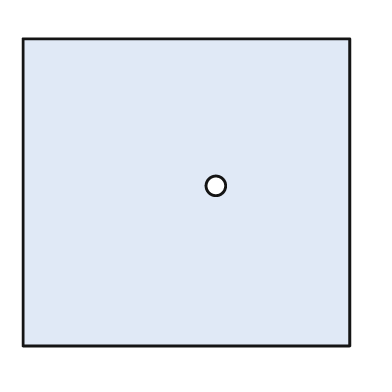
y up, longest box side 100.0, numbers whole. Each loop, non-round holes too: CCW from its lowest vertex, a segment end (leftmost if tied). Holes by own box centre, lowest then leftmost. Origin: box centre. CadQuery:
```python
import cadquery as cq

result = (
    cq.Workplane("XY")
    .moveTo(-50.0, -47.0)
    .lineTo(50.0, -47.0)
    .lineTo(50.0, 47.0)
    .lineTo(-50.0, 47.0)
    .close()
    .moveTo(9.0, 2.0)
    .circle(3.0)
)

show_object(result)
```